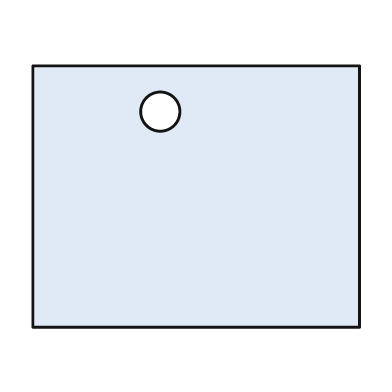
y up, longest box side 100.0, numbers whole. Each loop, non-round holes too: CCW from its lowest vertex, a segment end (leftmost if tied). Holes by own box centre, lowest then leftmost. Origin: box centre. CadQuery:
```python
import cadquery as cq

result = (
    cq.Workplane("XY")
    .moveTo(-50.0, -40.0)
    .lineTo(50.0, -40.0)
    .lineTo(50.0, 40.0)
    .lineTo(-50.0, 40.0)
    .close()
    .moveTo(-11.0, 26.0)
    .circle(6.0)
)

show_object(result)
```